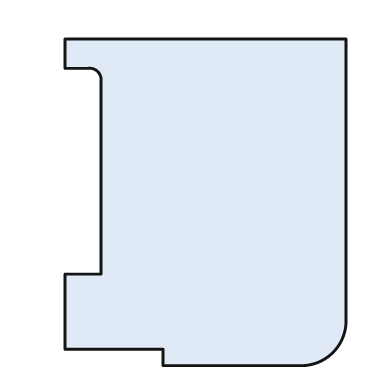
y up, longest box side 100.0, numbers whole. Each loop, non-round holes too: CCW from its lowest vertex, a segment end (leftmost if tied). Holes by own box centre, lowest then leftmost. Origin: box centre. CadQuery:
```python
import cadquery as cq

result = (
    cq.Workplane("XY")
    .moveTo(-13.0, -50.0)
    .lineTo(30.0, -50.0)
    .threePointArc((39.0, -46.0), (43.0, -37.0))
    .lineTo(43.0, 50.0)
    .lineTo(-43.0, 50.0)
    .lineTo(-43.0, 41.0)
    .lineTo(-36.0, 41.0)
    .threePointArc((-33.0, 40.0), (-32.0, 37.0))
    .lineTo(-32.0, -22.0)
    .lineTo(-43.0, -22.0)
    .lineTo(-43.0, -45.0)
    .lineTo(-13.0, -45.0)
    .close()
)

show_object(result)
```